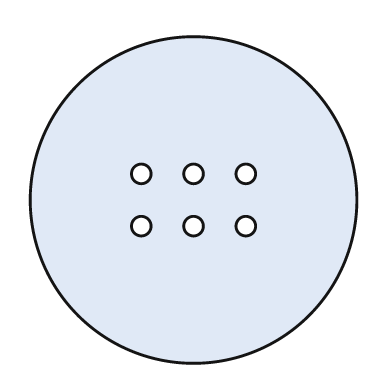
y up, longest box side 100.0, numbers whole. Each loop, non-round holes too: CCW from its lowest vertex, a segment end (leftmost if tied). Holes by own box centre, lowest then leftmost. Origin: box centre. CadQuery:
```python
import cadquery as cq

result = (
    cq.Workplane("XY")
    .moveTo(0.0, 0.0)
    .circle(50.0)
    .moveTo(-16.0, -8.0)
    .circle(3.0)
    .moveTo(0.0, -8.0)
    .circle(3.0)
    .moveTo(16.0, -8.0)
    .circle(3.0)
    .moveTo(-16.0, 8.0)
    .circle(3.0)
    .moveTo(0.0, 8.0)
    .circle(3.0)
    .moveTo(16.0, 8.0)
    .circle(3.0)
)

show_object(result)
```